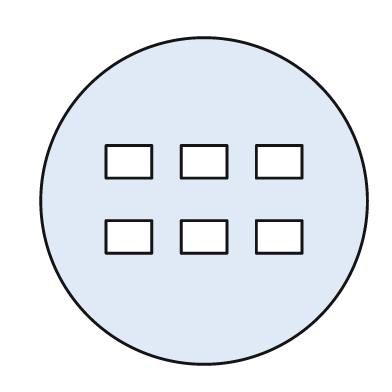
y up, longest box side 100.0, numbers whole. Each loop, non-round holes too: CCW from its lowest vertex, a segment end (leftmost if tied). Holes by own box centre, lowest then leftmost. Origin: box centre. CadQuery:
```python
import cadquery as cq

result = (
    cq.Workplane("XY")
    .moveTo(0.0, 0.0)
    .circle(50.0)
    .moveTo(-30.0, -16.0)
    .lineTo(-16.0, -16.0)
    .lineTo(-16.0, -6.0)
    .lineTo(-30.0, -6.0)
    .close()
    .moveTo(-7.0, -16.0)
    .lineTo(7.0, -16.0)
    .lineTo(7.0, -6.0)
    .lineTo(-7.0, -6.0)
    .close()
    .moveTo(16.0, -16.0)
    .lineTo(30.0, -16.0)
    .lineTo(30.0, -6.0)
    .lineTo(16.0, -6.0)
    .close()
    .moveTo(-30.0, 7.0)
    .lineTo(-16.0, 7.0)
    .lineTo(-16.0, 17.0)
    .lineTo(-30.0, 17.0)
    .close()
    .moveTo(-7.0, 7.0)
    .lineTo(7.0, 7.0)
    .lineTo(7.0, 17.0)
    .lineTo(-7.0, 17.0)
    .close()
    .moveTo(16.0, 7.0)
    .lineTo(30.0, 7.0)
    .lineTo(30.0, 17.0)
    .lineTo(16.0, 17.0)
    .close()
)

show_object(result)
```